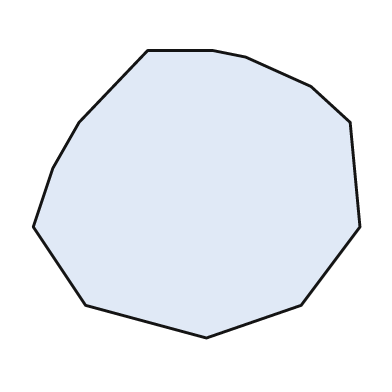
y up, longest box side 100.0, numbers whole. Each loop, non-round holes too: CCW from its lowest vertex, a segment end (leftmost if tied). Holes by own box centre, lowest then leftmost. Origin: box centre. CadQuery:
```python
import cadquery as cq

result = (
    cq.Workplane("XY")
    .moveTo(3.0, -44.0)
    .lineTo(32.0, -34.0)
    .lineTo(50.0, -10.0)
    .lineTo(47.0, 22.0)
    .lineTo(35.0, 33.0)
    .lineTo(15.0, 42.0)
    .lineTo(5.0, 44.0)
    .lineTo(-15.0, 44.0)
    .lineTo(-36.0, 22.0)
    .lineTo(-44.0, 8.0)
    .lineTo(-50.0, -10.0)
    .lineTo(-34.0, -34.0)
    .close()
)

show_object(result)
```